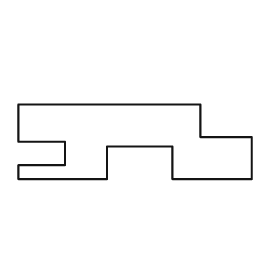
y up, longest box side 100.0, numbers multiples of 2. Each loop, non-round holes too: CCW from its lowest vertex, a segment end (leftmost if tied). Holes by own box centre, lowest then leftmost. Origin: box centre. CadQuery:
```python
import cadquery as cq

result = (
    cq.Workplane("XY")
    .moveTo(-50.0, -16.0)
    .lineTo(-12.0, -16.0)
    .lineTo(-12.0, -2.0)
    .lineTo(16.0, -2.0)
    .lineTo(16.0, -16.0)
    .lineTo(50.0, -16.0)
    .lineTo(50.0, 2.0)
    .lineTo(28.0, 2.0)
    .lineTo(28.0, 16.0)
    .lineTo(-50.0, 16.0)
    .lineTo(-50.0, 0.0)
    .lineTo(-30.0, 0.0)
    .lineTo(-30.0, -10.0)
    .lineTo(-50.0, -10.0)
    .close()
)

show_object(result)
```